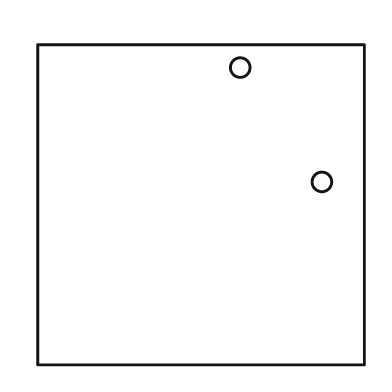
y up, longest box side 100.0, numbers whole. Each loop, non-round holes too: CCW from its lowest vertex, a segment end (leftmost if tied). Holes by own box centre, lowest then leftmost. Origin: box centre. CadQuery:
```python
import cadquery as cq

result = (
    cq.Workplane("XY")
    .moveTo(-50.0, -49.0)
    .lineTo(50.0, -49.0)
    .lineTo(50.0, 49.0)
    .lineTo(-50.0, 49.0)
    .close()
    .moveTo(37.0, 7.0)
    .circle(3.0)
    .moveTo(12.0, 42.0)
    .circle(3.0)
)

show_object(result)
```